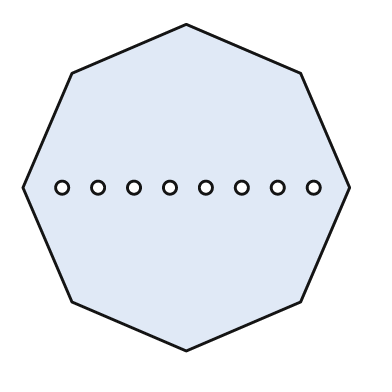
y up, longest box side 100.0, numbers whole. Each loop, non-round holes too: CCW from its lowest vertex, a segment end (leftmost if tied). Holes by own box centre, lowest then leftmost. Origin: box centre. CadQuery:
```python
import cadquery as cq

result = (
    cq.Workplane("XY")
    .moveTo(0.0, -50.0)
    .lineTo(35.0, -35.0)
    .lineTo(50.0, 0.0)
    .lineTo(35.0, 35.0)
    .lineTo(0.0, 50.0)
    .lineTo(-35.0, 35.0)
    .lineTo(-50.0, 0.0)
    .lineTo(-35.0, -35.0)
    .close()
    .moveTo(-38.0, 0.0)
    .circle(2.0)
    .moveTo(-27.0, 0.0)
    .circle(2.0)
    .moveTo(-16.0, 0.0)
    .circle(2.0)
    .moveTo(-5.0, 0.0)
    .circle(2.0)
    .moveTo(6.0, 0.0)
    .circle(2.0)
    .moveTo(17.0, 0.0)
    .circle(2.0)
    .moveTo(28.0, 0.0)
    .circle(2.0)
    .moveTo(39.0, 0.0)
    .circle(2.0)
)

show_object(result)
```